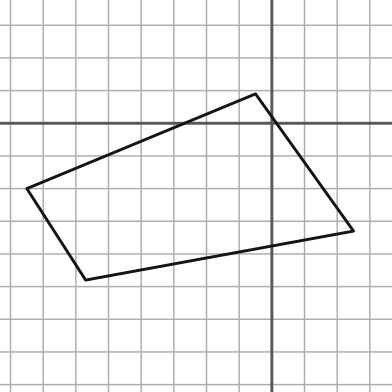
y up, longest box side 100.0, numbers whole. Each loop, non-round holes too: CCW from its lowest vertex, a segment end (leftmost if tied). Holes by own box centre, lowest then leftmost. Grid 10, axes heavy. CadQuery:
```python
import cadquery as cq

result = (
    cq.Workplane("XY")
    .moveTo(-57.0, -48.0)
    .lineTo(25.0, -33.0)
    .lineTo(-5.0, 9.0)
    .lineTo(-75.0, -20.0)
    .close()
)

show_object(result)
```